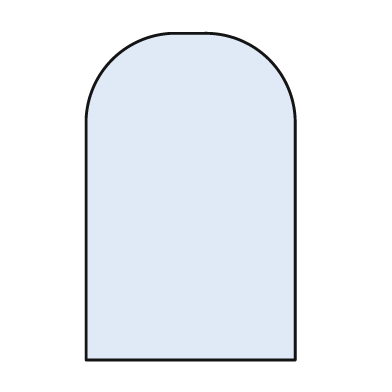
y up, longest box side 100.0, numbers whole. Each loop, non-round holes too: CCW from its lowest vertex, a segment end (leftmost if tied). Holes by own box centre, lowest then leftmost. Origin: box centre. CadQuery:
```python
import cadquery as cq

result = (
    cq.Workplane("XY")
    .moveTo(-32.0, -50.0)
    .lineTo(32.0, -50.0)
    .lineTo(32.0, 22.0)
    .threePointArc((24.0, 42.0), (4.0, 50.0))
    .lineTo(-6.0, 50.0)
    .threePointArc((-24.0, 42.0), (-32.0, 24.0))
    .close()
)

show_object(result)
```